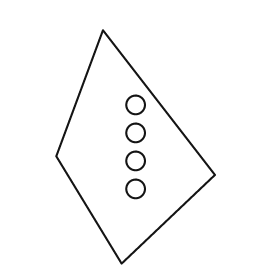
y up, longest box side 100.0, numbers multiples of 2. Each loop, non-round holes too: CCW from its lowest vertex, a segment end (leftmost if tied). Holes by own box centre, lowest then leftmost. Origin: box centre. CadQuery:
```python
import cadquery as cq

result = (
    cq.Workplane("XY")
    .moveTo(-6.0, -50.0)
    .lineTo(34.0, -12.0)
    .lineTo(-14.0, 50.0)
    .lineTo(-34.0, -4.0)
    .close()
    .moveTo(0.0, -18.0)
    .circle(4.0)
    .moveTo(0.0, -6.0)
    .circle(4.0)
    .moveTo(0.0, 6.0)
    .circle(4.0)
    .moveTo(0.0, 18.0)
    .circle(4.0)
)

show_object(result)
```